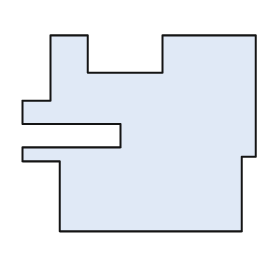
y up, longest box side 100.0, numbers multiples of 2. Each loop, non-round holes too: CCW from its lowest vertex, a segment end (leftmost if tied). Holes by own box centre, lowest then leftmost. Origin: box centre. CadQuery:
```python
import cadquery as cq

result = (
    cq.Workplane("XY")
    .moveTo(-34.0, -42.0)
    .lineTo(44.0, -42.0)
    .lineTo(44.0, -10.0)
    .lineTo(50.0, -10.0)
    .lineTo(50.0, 42.0)
    .lineTo(10.0, 42.0)
    .lineTo(10.0, 26.0)
    .lineTo(-22.0, 26.0)
    .lineTo(-22.0, 42.0)
    .lineTo(-38.0, 42.0)
    .lineTo(-38.0, 14.0)
    .lineTo(-50.0, 14.0)
    .lineTo(-50.0, 4.0)
    .lineTo(-8.0, 4.0)
    .lineTo(-8.0, -6.0)
    .lineTo(-50.0, -6.0)
    .lineTo(-50.0, -12.0)
    .lineTo(-34.0, -12.0)
    .close()
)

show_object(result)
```